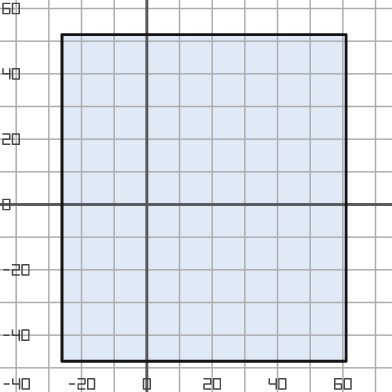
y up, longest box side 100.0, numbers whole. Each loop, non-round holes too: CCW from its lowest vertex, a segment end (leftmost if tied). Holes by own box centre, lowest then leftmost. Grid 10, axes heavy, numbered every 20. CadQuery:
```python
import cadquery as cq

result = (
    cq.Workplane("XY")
    .moveTo(-26.0, -48.0)
    .lineTo(61.0, -48.0)
    .lineTo(61.0, 52.0)
    .lineTo(-26.0, 52.0)
    .close()
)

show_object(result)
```